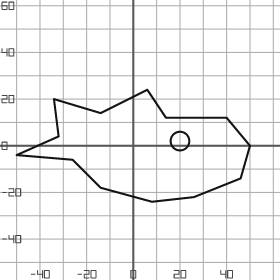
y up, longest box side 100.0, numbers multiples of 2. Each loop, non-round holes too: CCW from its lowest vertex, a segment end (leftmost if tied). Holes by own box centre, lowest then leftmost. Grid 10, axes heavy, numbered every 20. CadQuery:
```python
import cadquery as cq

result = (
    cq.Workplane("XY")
    .moveTo(8.0, -24.0)
    .lineTo(26.0, -22.0)
    .lineTo(46.0, -14.0)
    .lineTo(50.0, 0.0)
    .lineTo(40.0, 12.0)
    .lineTo(14.0, 12.0)
    .lineTo(6.0, 24.0)
    .lineTo(-14.0, 14.0)
    .lineTo(-34.0, 20.0)
    .lineTo(-32.0, 4.0)
    .lineTo(-50.0, -4.0)
    .lineTo(-26.0, -6.0)
    .lineTo(-14.0, -18.0)
    .close()
    .moveTo(20.0, 2.0)
    .circle(4.0)
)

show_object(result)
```